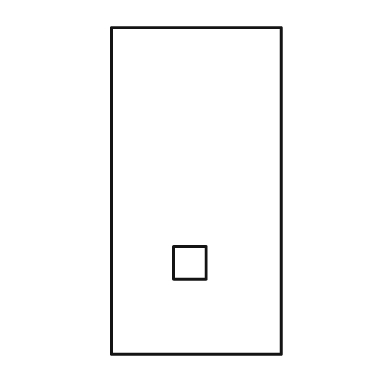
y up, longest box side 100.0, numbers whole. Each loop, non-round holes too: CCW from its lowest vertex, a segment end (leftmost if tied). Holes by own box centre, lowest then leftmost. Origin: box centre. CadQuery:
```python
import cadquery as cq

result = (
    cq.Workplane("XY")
    .moveTo(-26.0, -50.0)
    .lineTo(26.0, -50.0)
    .lineTo(26.0, 50.0)
    .lineTo(-26.0, 50.0)
    .close()
    .moveTo(-7.0, -27.0)
    .lineTo(3.0, -27.0)
    .lineTo(3.0, -17.0)
    .lineTo(-7.0, -17.0)
    .close()
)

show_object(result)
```